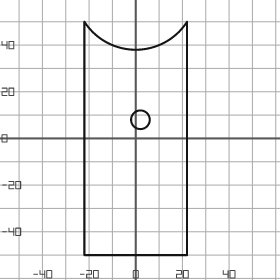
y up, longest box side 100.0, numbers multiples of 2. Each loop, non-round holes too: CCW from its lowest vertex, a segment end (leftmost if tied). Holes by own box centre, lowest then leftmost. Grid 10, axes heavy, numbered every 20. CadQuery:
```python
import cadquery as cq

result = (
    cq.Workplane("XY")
    .moveTo(-22.0, -50.0)
    .lineTo(22.0, -50.0)
    .lineTo(22.0, 50.0)
    .threePointArc((0.0, 38.0), (-22.0, 50.0))
    .close()
    .moveTo(2.0, 8.0)
    .circle(4.0)
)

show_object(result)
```